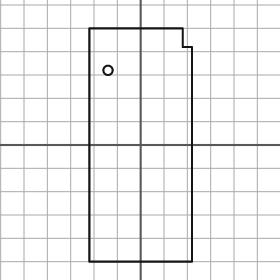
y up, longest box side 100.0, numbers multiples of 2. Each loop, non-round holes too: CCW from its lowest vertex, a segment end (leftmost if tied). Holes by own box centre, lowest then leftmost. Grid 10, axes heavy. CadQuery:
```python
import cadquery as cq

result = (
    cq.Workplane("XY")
    .moveTo(-22.0, -50.0)
    .lineTo(22.0, -50.0)
    .lineTo(22.0, 42.0)
    .lineTo(18.0, 42.0)
    .lineTo(18.0, 50.0)
    .lineTo(-22.0, 50.0)
    .close()
    .moveTo(-14.0, 32.0)
    .circle(2.0)
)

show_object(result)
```